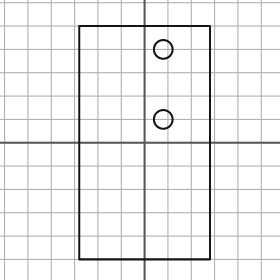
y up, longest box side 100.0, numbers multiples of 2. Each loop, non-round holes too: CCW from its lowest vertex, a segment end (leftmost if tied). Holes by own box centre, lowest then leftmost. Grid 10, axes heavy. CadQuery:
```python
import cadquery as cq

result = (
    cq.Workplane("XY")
    .moveTo(-28.0, -50.0)
    .lineTo(28.0, -50.0)
    .lineTo(28.0, 50.0)
    .lineTo(-28.0, 50.0)
    .close()
    .moveTo(8.0, 10.0)
    .circle(4.0)
    .moveTo(8.0, 40.0)
    .circle(4.0)
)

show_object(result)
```